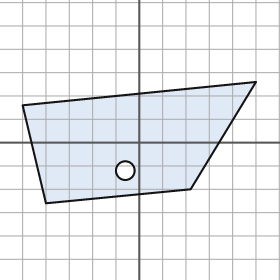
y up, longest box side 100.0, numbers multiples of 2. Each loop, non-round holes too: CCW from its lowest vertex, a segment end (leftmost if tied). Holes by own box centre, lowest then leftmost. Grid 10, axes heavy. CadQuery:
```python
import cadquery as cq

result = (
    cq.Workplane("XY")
    .moveTo(-40.0, -26.0)
    .lineTo(22.0, -20.0)
    .lineTo(50.0, 26.0)
    .lineTo(-50.0, 16.0)
    .close()
    .moveTo(-6.0, -12.0)
    .circle(4.0)
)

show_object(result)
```